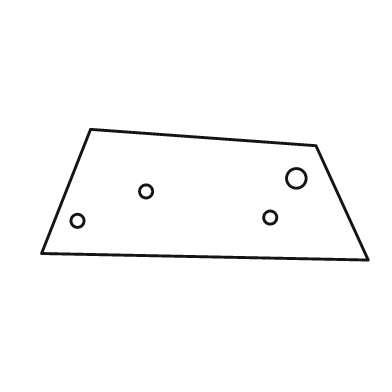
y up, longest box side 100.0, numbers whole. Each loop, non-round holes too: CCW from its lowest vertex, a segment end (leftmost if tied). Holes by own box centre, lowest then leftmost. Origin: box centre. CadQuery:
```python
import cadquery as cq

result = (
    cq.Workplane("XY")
    .moveTo(50.0, -20.0)
    .lineTo(34.0, 15.0)
    .lineTo(-35.0, 20.0)
    .lineTo(-50.0, -18.0)
    .close()
    .moveTo(-39.0, -8.0)
    .circle(2.0)
    .moveTo(20.0, -7.0)
    .circle(2.0)
    .moveTo(-18.0, 1.0)
    .circle(2.0)
    .moveTo(28.0, 5.0)
    .circle(3.0)
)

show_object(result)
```